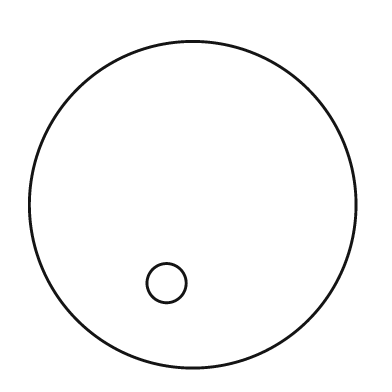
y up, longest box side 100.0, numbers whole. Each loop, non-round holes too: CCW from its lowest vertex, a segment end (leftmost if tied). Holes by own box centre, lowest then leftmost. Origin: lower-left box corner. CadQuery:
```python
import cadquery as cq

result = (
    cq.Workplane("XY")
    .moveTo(50.0, 50.0)
    .circle(50.0)
    .moveTo(42.0, 26.0)
    .circle(6.0)
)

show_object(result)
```